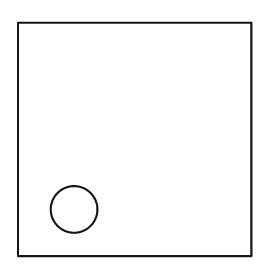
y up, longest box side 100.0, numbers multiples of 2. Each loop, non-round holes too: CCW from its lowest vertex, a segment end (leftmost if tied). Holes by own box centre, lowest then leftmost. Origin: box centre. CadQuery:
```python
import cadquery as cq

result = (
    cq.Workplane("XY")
    .moveTo(-50.0, -50.0)
    .lineTo(50.0, -50.0)
    .lineTo(50.0, 50.0)
    .lineTo(-50.0, 50.0)
    .close()
    .moveTo(-26.0, -30.0)
    .circle(10.0)
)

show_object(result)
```